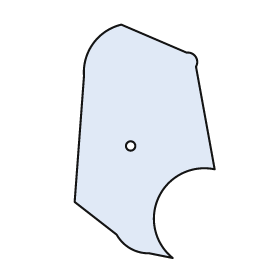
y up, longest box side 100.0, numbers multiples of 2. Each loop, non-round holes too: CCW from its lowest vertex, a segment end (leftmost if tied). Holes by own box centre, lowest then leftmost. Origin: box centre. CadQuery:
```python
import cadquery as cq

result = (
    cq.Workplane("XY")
    .moveTo(12.0, -50.0)
    .threePointArc((6.0, -24.0), (30.0, -12.0))
    .lineTo(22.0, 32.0)
    .threePointArc((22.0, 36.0), (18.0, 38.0))
    .lineTo(-10.0, 50.0)
    .threePointArc((-22.0, 42.0), (-26.0, 28.0))
    .lineTo(-30.0, -26.0)
    .lineTo(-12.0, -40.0)
    .threePointArc((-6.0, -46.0), (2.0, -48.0))
    .close()
    .moveTo(-6.0, -2.0)
    .circle(2.0)
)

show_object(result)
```